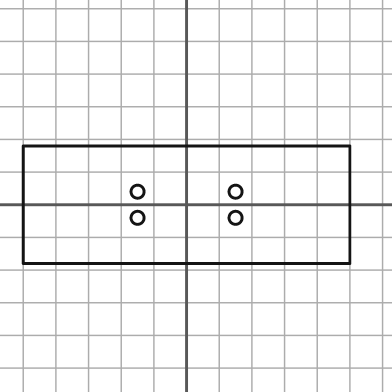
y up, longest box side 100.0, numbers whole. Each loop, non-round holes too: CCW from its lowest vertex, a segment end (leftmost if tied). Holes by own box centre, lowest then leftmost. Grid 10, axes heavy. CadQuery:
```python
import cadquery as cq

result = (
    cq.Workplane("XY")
    .moveTo(-50.0, -18.0)
    .lineTo(50.0, -18.0)
    .lineTo(50.0, 18.0)
    .lineTo(-50.0, 18.0)
    .close()
    .moveTo(-15.0, -4.0)
    .circle(2.0)
    .moveTo(15.0, -4.0)
    .circle(2.0)
    .moveTo(-15.0, 4.0)
    .circle(2.0)
    .moveTo(15.0, 4.0)
    .circle(2.0)
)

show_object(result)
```